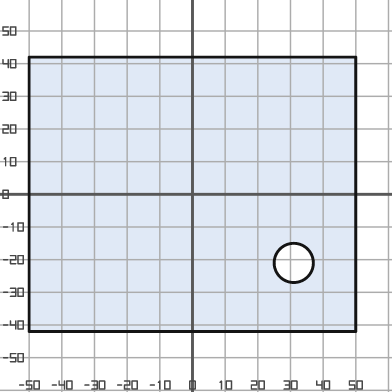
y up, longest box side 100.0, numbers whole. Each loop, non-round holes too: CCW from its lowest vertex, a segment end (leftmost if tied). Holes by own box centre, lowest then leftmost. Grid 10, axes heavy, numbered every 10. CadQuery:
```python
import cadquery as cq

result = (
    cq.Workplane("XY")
    .moveTo(-50.0, -42.0)
    .lineTo(50.0, -42.0)
    .lineTo(50.0, 42.0)
    .lineTo(-50.0, 42.0)
    .close()
    .moveTo(31.0, -21.0)
    .circle(6.0)
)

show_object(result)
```